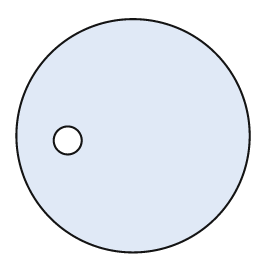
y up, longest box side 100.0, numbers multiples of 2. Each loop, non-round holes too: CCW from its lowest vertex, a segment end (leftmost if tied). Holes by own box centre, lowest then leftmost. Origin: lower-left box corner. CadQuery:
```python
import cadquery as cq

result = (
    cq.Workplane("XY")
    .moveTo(50.0, 50.0)
    .circle(50.0)
    .moveTo(22.0, 48.0)
    .circle(6.0)
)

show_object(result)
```